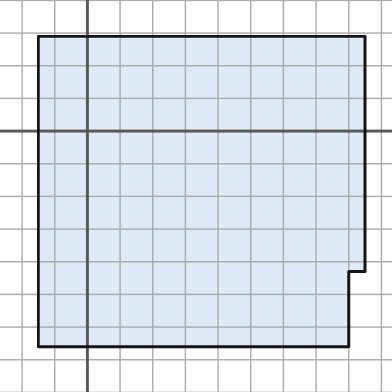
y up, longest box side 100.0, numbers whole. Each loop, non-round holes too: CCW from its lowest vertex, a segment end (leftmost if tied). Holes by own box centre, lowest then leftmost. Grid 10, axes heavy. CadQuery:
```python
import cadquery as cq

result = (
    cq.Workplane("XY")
    .moveTo(-15.0, -66.0)
    .lineTo(80.0, -66.0)
    .lineTo(80.0, -43.0)
    .lineTo(85.0, -43.0)
    .lineTo(85.0, 29.0)
    .lineTo(-15.0, 29.0)
    .close()
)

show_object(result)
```